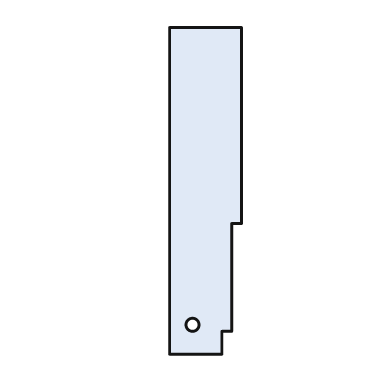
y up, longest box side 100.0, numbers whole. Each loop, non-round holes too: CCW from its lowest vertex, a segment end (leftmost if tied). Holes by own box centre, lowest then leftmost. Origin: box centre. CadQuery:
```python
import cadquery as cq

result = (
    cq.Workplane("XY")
    .moveTo(-11.0, -50.0)
    .lineTo(5.0, -50.0)
    .lineTo(5.0, -43.0)
    .lineTo(8.0, -43.0)
    .lineTo(8.0, -10.0)
    .lineTo(11.0, -10.0)
    .lineTo(11.0, 50.0)
    .lineTo(-11.0, 50.0)
    .close()
    .moveTo(-4.0, -41.0)
    .circle(2.0)
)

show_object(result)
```